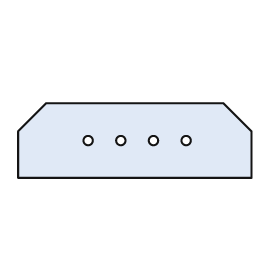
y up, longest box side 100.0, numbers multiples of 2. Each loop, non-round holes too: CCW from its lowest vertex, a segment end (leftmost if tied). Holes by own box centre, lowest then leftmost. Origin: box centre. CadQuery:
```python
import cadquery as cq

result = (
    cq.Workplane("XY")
    .moveTo(-50.0, -16.0)
    .lineTo(50.0, -16.0)
    .lineTo(50.0, 4.0)
    .lineTo(38.0, 16.0)
    .lineTo(-38.0, 16.0)
    .lineTo(-50.0, 4.0)
    .close()
    .moveTo(-20.0, 0.0)
    .circle(2.0)
    .moveTo(-6.0, 0.0)
    .circle(2.0)
    .moveTo(8.0, 0.0)
    .circle(2.0)
    .moveTo(22.0, 0.0)
    .circle(2.0)
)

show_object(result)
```